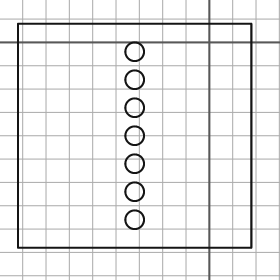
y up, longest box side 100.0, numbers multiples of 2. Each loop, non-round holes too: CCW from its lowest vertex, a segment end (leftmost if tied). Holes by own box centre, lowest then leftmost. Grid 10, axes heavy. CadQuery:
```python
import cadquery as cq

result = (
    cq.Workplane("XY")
    .moveTo(-82.0, -88.0)
    .lineTo(18.0, -88.0)
    .lineTo(18.0, 8.0)
    .lineTo(-82.0, 8.0)
    .close()
    .moveTo(-32.0, -76.0)
    .circle(4.0)
    .moveTo(-32.0, -64.0)
    .circle(4.0)
    .moveTo(-32.0, -52.0)
    .circle(4.0)
    .moveTo(-32.0, -40.0)
    .circle(4.0)
    .moveTo(-32.0, -28.0)
    .circle(4.0)
    .moveTo(-32.0, -16.0)
    .circle(4.0)
    .moveTo(-32.0, -4.0)
    .circle(4.0)
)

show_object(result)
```